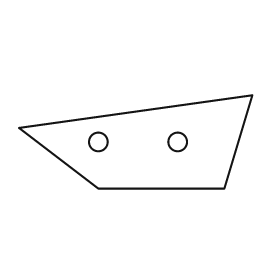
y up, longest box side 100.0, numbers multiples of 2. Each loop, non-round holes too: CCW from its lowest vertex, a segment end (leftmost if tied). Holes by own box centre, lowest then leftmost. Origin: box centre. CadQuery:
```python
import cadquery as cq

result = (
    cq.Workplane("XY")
    .moveTo(-16.0, -20.0)
    .lineTo(38.0, -20.0)
    .lineTo(50.0, 20.0)
    .lineTo(-50.0, 6.0)
    .close()
    .moveTo(-16.0, 0.0)
    .circle(4.0)
    .moveTo(18.0, 0.0)
    .circle(4.0)
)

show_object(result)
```